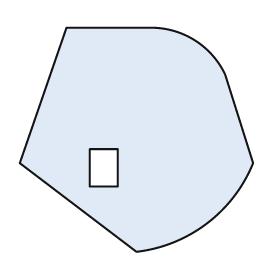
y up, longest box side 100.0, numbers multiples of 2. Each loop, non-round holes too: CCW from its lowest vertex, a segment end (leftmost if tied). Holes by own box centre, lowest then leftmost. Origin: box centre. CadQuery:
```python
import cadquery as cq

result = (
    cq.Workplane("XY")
    .moveTo(0.0, -48.0)
    .threePointArc((30.0, -36.0), (50.0, -10.0))
    .lineTo(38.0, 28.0)
    .threePointArc((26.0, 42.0), (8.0, 48.0))
    .lineTo(-30.0, 48.0)
    .lineTo(-50.0, -10.0)
    .close()
    .moveTo(-20.0, -20.0)
    .lineTo(-8.0, -20.0)
    .lineTo(-8.0, -4.0)
    .lineTo(-20.0, -4.0)
    .close()
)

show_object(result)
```